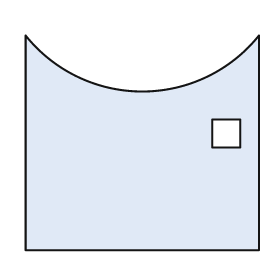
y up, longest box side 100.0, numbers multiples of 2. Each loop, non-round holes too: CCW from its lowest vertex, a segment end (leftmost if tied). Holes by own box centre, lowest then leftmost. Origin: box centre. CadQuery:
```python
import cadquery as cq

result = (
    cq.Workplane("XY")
    .moveTo(-50.0, -46.0)
    .lineTo(50.0, -46.0)
    .lineTo(50.0, 46.0)
    .threePointArc((0.0, 22.0), (-50.0, 46.0))
    .close()
    .moveTo(30.0, -2.0)
    .lineTo(42.0, -2.0)
    .lineTo(42.0, 10.0)
    .lineTo(30.0, 10.0)
    .close()
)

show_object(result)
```